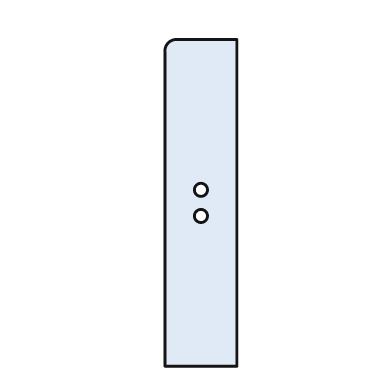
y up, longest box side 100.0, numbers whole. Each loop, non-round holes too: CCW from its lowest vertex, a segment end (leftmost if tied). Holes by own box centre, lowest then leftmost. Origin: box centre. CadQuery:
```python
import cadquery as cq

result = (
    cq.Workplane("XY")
    .moveTo(-11.0, -50.0)
    .lineTo(11.0, -50.0)
    .lineTo(11.0, 50.0)
    .lineTo(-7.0, 50.0)
    .threePointArc((-10.0, 49.0), (-11.0, 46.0))
    .close()
    .moveTo(0.0, -4.0)
    .circle(2.0)
    .moveTo(0.0, 4.0)
    .circle(2.0)
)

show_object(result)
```